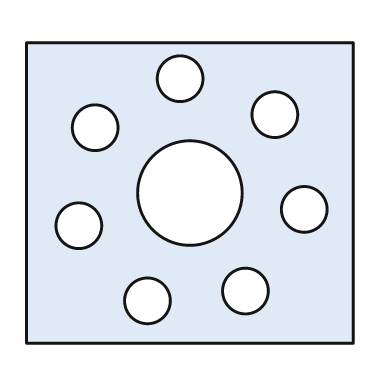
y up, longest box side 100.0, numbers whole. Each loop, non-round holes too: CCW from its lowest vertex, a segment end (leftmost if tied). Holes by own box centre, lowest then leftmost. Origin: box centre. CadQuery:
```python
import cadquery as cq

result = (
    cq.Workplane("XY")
    .moveTo(-50.0, -46.0)
    .lineTo(50.0, -46.0)
    .lineTo(50.0, 46.0)
    .lineTo(-50.0, 46.0)
    .close()
    .moveTo(-13.0, -33.0)
    .circle(7.0)
    .moveTo(17.0, -30.0)
    .circle(7.0)
    .moveTo(-34.0, -10.0)
    .circle(7.0)
    .moveTo(35.0, -5.0)
    .circle(7.0)
    .moveTo(0.0, 0.0)
    .circle(16.0)
    .moveTo(-29.0, 20.0)
    .circle(7.0)
    .moveTo(26.0, 24.0)
    .circle(7.0)
    .moveTo(-3.0, 35.0)
    .circle(7.0)
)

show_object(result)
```